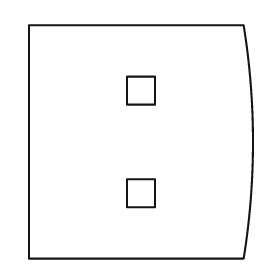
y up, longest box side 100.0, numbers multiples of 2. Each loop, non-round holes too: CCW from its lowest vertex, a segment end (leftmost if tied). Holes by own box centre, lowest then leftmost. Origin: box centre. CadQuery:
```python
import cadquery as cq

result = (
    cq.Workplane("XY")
    .moveTo(-48.0, -50.0)
    .lineTo(44.0, -50.0)
    .threePointArc((48.0, 0.0), (44.0, 50.0))
    .lineTo(-48.0, 50.0)
    .close()
    .moveTo(-6.0, -28.0)
    .lineTo(6.0, -28.0)
    .lineTo(6.0, -16.0)
    .lineTo(-6.0, -16.0)
    .close()
    .moveTo(-6.0, 16.0)
    .lineTo(6.0, 16.0)
    .lineTo(6.0, 28.0)
    .lineTo(-6.0, 28.0)
    .close()
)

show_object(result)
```